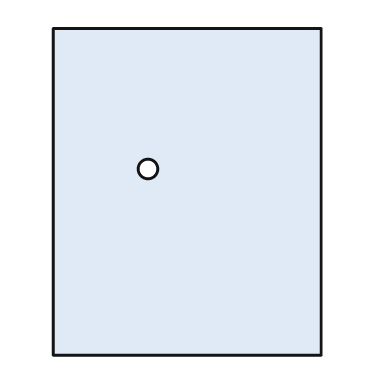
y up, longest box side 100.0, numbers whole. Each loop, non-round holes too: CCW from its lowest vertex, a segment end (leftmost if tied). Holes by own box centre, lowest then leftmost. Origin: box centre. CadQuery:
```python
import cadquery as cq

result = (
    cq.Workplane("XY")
    .moveTo(-41.0, -50.0)
    .lineTo(41.0, -50.0)
    .lineTo(41.0, 50.0)
    .lineTo(-41.0, 50.0)
    .close()
    .moveTo(-12.0, 7.0)
    .circle(3.0)
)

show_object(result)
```